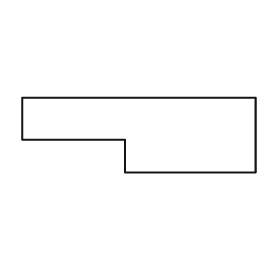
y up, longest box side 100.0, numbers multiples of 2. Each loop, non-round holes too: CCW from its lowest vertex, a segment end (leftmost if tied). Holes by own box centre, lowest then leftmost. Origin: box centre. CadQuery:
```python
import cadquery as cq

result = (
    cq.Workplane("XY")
    .moveTo(-6.0, -16.0)
    .lineTo(50.0, -16.0)
    .lineTo(50.0, 16.0)
    .lineTo(-50.0, 16.0)
    .lineTo(-50.0, -2.0)
    .lineTo(-6.0, -2.0)
    .close()
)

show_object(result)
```